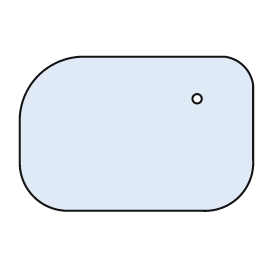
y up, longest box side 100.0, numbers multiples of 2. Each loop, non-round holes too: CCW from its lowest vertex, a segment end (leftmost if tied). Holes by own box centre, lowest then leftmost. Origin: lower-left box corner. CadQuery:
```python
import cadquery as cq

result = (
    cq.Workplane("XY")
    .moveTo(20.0, 0.0)
    .lineTo(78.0, 0.0)
    .threePointArc((94.0, 6.0), (100.0, 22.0))
    .lineTo(100.0, 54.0)
    .threePointArc((96.0, 62.0), (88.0, 66.0))
    .lineTo(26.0, 66.0)
    .threePointArc((8.0, 58.0), (0.0, 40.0))
    .lineTo(0.0, 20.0)
    .threePointArc((6.0, 6.0), (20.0, 0.0))
    .close()
    .moveTo(76.0, 48.0)
    .circle(2.0)
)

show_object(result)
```